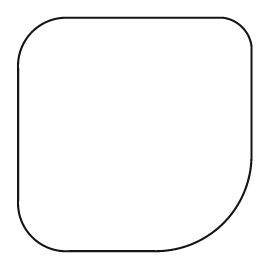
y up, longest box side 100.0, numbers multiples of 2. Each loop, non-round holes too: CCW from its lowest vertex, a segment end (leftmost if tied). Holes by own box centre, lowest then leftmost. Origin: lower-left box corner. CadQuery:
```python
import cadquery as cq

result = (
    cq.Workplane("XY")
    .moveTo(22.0, 0.0)
    .lineTo(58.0, 0.0)
    .threePointArc((88.0, 12.0), (100.0, 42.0))
    .lineTo(100.0, 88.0)
    .threePointArc((96.0, 96.0), (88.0, 100.0))
    .lineTo(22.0, 100.0)
    .threePointArc((6.0, 94.0), (0.0, 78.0))
    .lineTo(0.0, 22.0)
    .threePointArc((6.0, 6.0), (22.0, 0.0))
    .close()
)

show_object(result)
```